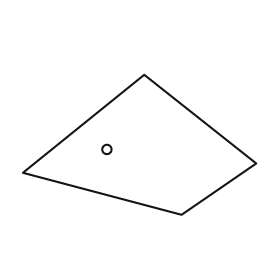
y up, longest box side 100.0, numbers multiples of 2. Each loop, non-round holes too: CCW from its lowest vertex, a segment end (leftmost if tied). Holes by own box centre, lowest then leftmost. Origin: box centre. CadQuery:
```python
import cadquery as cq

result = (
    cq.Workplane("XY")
    .moveTo(18.0, -30.0)
    .lineTo(50.0, -8.0)
    .lineTo(2.0, 30.0)
    .lineTo(-50.0, -12.0)
    .close()
    .moveTo(-14.0, -2.0)
    .circle(2.0)
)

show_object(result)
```